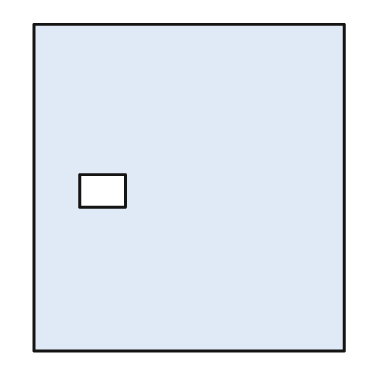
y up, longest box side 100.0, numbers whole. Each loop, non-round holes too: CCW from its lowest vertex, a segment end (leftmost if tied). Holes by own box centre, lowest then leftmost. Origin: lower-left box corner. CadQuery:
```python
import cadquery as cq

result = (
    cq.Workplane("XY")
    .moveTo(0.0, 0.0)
    .lineTo(95.0, 0.0)
    .lineTo(95.0, 100.0)
    .lineTo(0.0, 100.0)
    .close()
    .moveTo(14.0, 44.0)
    .lineTo(28.0, 44.0)
    .lineTo(28.0, 54.0)
    .lineTo(14.0, 54.0)
    .close()
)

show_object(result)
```